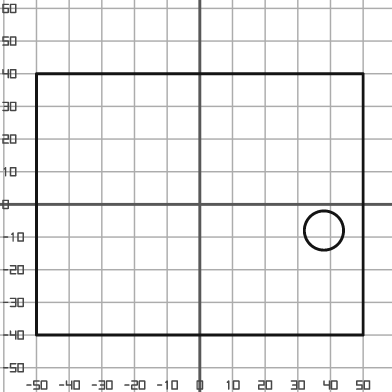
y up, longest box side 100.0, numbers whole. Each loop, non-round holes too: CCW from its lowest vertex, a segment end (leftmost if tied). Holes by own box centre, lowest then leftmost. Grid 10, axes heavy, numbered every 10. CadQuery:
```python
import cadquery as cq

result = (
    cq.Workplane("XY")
    .moveTo(-50.0, -40.0)
    .lineTo(50.0, -40.0)
    .lineTo(50.0, 40.0)
    .lineTo(-50.0, 40.0)
    .close()
    .moveTo(38.0, -8.0)
    .circle(6.0)
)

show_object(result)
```